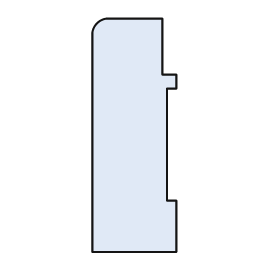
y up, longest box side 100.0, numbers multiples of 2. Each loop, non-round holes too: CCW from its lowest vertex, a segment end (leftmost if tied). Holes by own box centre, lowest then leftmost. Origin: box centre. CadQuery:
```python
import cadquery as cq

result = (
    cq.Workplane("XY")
    .moveTo(-18.0, -50.0)
    .lineTo(18.0, -50.0)
    .lineTo(18.0, -28.0)
    .lineTo(14.0, -28.0)
    .lineTo(14.0, 20.0)
    .lineTo(18.0, 20.0)
    .lineTo(18.0, 26.0)
    .lineTo(12.0, 26.0)
    .lineTo(12.0, 50.0)
    .lineTo(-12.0, 50.0)
    .threePointArc((-16.0, 48.0), (-18.0, 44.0))
    .close()
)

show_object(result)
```